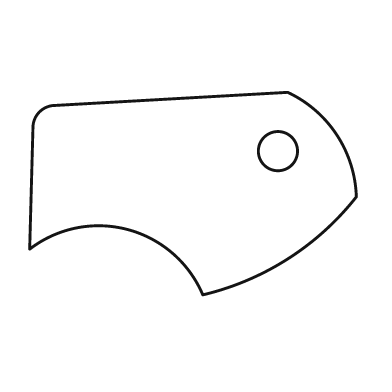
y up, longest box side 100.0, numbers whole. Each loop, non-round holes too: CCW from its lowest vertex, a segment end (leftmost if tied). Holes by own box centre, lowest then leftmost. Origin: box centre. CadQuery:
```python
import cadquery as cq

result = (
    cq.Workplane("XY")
    .moveTo(3.0, -31.0)
    .threePointArc((29.0, -20.0), (50.0, -1.0))
    .threePointArc((44.0, 18.0), (29.0, 31.0))
    .lineTo(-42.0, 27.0)
    .threePointArc((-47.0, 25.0), (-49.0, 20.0))
    .lineTo(-50.0, -17.0)
    .threePointArc((-20.0, -11.0), (3.0, -31.0))
    .close()
    .moveTo(26.0, 13.0)
    .circle(6.0)
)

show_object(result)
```